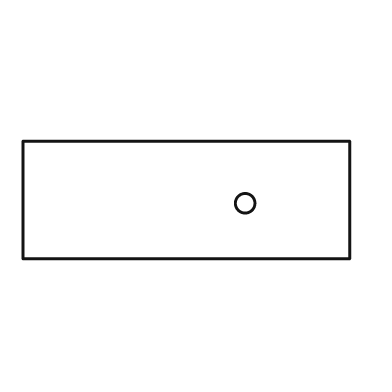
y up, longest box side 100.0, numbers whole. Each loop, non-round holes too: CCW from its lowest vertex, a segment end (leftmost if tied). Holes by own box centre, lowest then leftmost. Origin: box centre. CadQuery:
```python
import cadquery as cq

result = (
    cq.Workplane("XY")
    .moveTo(-50.0, -18.0)
    .lineTo(50.0, -18.0)
    .lineTo(50.0, 18.0)
    .lineTo(-50.0, 18.0)
    .close()
    .moveTo(18.0, -1.0)
    .circle(3.0)
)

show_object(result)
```